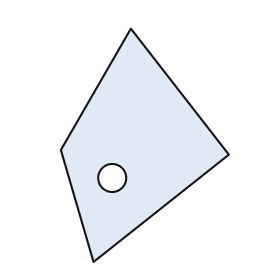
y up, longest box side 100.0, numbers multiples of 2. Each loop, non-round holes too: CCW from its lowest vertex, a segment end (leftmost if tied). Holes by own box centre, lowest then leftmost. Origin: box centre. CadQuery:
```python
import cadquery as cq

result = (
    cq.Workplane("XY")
    .moveTo(-22.0, -50.0)
    .lineTo(36.0, -4.0)
    .lineTo(-6.0, 50.0)
    .lineTo(-36.0, -2.0)
    .close()
    .moveTo(-14.0, -14.0)
    .circle(6.0)
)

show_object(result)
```